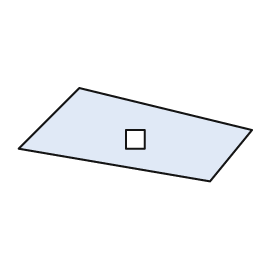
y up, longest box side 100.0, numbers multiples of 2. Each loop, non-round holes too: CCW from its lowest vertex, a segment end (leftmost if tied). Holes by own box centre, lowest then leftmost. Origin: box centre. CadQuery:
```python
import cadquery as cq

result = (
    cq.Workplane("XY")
    .moveTo(32.0, -20.0)
    .lineTo(50.0, 2.0)
    .lineTo(-24.0, 20.0)
    .lineTo(-50.0, -6.0)
    .close()
    .moveTo(-4.0, -6.0)
    .lineTo(4.0, -6.0)
    .lineTo(4.0, 2.0)
    .lineTo(-4.0, 2.0)
    .close()
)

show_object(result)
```